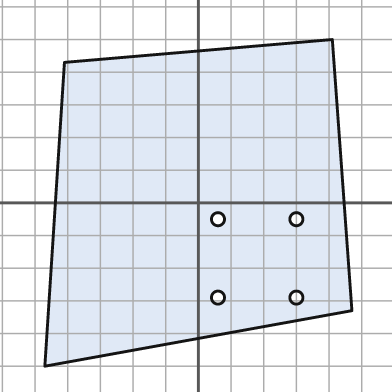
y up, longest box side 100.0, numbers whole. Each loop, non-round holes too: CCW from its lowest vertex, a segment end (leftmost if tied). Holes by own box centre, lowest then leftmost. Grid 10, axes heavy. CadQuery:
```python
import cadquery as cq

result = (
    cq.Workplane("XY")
    .moveTo(-47.0, -50.0)
    .lineTo(47.0, -33.0)
    .lineTo(41.0, 50.0)
    .lineTo(-41.0, 43.0)
    .close()
    .moveTo(6.0, -29.0)
    .circle(2.0)
    .moveTo(30.0, -29.0)
    .circle(2.0)
    .moveTo(6.0, -5.0)
    .circle(2.0)
    .moveTo(30.0, -5.0)
    .circle(2.0)
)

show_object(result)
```